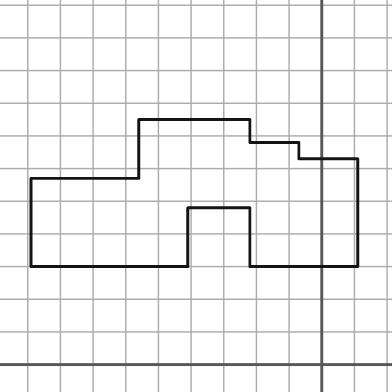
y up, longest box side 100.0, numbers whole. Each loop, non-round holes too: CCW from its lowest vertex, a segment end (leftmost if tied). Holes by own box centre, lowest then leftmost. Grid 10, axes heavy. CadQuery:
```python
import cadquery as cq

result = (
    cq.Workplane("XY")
    .moveTo(-89.0, 30.0)
    .lineTo(-41.0, 30.0)
    .lineTo(-41.0, 48.0)
    .lineTo(-22.0, 48.0)
    .lineTo(-22.0, 30.0)
    .lineTo(11.0, 30.0)
    .lineTo(11.0, 63.0)
    .lineTo(-7.0, 63.0)
    .lineTo(-7.0, 68.0)
    .lineTo(-22.0, 68.0)
    .lineTo(-22.0, 75.0)
    .lineTo(-56.0, 75.0)
    .lineTo(-56.0, 57.0)
    .lineTo(-89.0, 57.0)
    .close()
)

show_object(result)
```